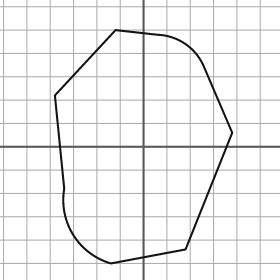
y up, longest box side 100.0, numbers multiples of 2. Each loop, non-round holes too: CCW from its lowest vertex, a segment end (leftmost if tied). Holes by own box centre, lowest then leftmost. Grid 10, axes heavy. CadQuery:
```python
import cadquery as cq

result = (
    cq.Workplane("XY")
    .moveTo(-14.0, -50.0)
    .lineTo(18.0, -44.0)
    .lineTo(38.0, 6.0)
    .lineTo(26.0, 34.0)
    .threePointArc((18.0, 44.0), (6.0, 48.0))
    .lineTo(-12.0, 50.0)
    .lineTo(-38.0, 22.0)
    .lineTo(-34.0, -18.0)
    .threePointArc((-30.0, -38.0), (-14.0, -50.0))
    .close()
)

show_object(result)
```